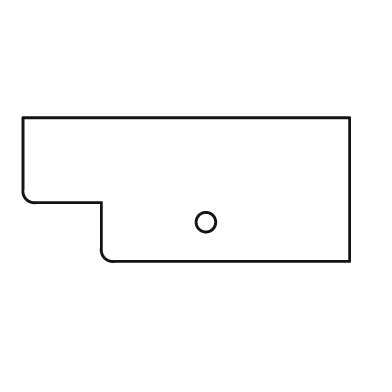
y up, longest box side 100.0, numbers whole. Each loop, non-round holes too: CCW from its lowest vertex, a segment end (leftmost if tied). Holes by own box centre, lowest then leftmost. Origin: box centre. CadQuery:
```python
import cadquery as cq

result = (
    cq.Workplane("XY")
    .moveTo(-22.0, -22.0)
    .lineTo(50.0, -22.0)
    .lineTo(50.0, 22.0)
    .lineTo(-50.0, 22.0)
    .lineTo(-50.0, 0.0)
    .threePointArc((-49.0, -3.0), (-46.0, -4.0))
    .lineTo(-26.0, -4.0)
    .lineTo(-26.0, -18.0)
    .threePointArc((-25.0, -21.0), (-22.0, -22.0))
    .close()
    .moveTo(6.0, -10.0)
    .circle(3.0)
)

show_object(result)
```